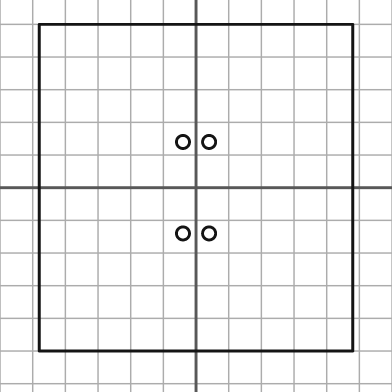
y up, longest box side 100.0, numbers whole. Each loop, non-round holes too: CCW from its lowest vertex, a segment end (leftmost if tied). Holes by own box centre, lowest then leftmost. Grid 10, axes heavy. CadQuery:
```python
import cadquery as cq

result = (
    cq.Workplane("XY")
    .moveTo(-48.0, -50.0)
    .lineTo(48.0, -50.0)
    .lineTo(48.0, 50.0)
    .lineTo(-48.0, 50.0)
    .close()
    .moveTo(-4.0, -14.0)
    .circle(2.0)
    .moveTo(4.0, -14.0)
    .circle(2.0)
    .moveTo(-4.0, 14.0)
    .circle(2.0)
    .moveTo(4.0, 14.0)
    .circle(2.0)
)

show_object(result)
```